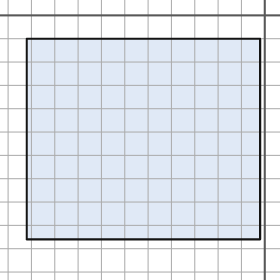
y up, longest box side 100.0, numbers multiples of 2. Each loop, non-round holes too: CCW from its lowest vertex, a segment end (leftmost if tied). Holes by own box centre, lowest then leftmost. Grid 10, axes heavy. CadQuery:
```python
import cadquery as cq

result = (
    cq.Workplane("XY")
    .moveTo(-102.0, -96.0)
    .lineTo(-2.0, -96.0)
    .lineTo(-2.0, -10.0)
    .lineTo(-102.0, -10.0)
    .close()
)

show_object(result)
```